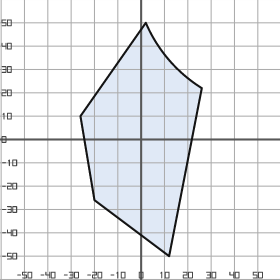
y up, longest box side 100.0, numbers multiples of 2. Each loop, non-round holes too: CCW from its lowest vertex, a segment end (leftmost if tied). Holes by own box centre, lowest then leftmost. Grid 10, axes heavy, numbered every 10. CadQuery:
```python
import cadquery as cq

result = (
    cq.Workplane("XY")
    .moveTo(12.0, -50.0)
    .lineTo(26.0, 22.0)
    .threePointArc((12.0, 34.0), (2.0, 50.0))
    .lineTo(-26.0, 10.0)
    .lineTo(-20.0, -26.0)
    .close()
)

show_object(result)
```